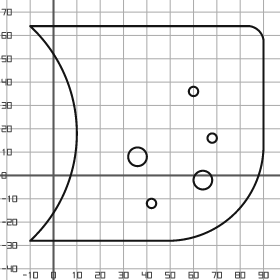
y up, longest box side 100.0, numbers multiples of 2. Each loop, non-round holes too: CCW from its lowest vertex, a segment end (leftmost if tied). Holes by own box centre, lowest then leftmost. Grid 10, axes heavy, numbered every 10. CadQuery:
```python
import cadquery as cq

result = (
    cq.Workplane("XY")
    .moveTo(-10.0, -28.0)
    .lineTo(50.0, -28.0)
    .threePointArc((78.0, -16.0), (90.0, 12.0))
    .lineTo(90.0, 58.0)
    .threePointArc((88.0, 62.0), (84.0, 64.0))
    .lineTo(-10.0, 64.0)
    .threePointArc((10.0, 18.0), (-10.0, -28.0))
    .close()
    .moveTo(42.0, -12.0)
    .circle(2.0)
    .moveTo(64.0, -2.0)
    .circle(4.0)
    .moveTo(36.0, 8.0)
    .circle(4.0)
    .moveTo(68.0, 16.0)
    .circle(2.0)
    .moveTo(60.0, 36.0)
    .circle(2.0)
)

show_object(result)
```